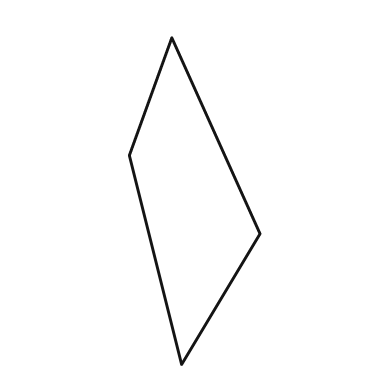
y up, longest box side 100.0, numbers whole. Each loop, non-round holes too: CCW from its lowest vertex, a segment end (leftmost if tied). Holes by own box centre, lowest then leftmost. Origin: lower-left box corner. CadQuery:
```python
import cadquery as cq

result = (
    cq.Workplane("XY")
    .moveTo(16.0, 0.0)
    .lineTo(40.0, 40.0)
    .lineTo(13.0, 100.0)
    .lineTo(0.0, 64.0)
    .close()
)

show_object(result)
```